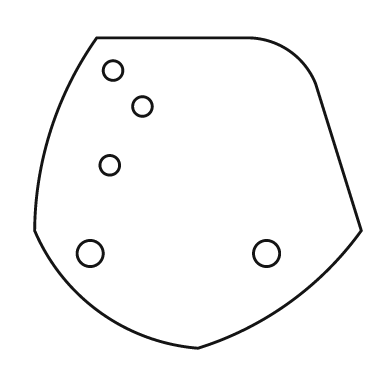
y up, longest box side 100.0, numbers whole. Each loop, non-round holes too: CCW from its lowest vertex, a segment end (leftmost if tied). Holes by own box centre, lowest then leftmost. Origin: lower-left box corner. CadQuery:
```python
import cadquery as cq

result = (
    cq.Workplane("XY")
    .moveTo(50.0, 0.0)
    .threePointArc((78.0, 14.0), (100.0, 36.0))
    .lineTo(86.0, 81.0)
    .threePointArc((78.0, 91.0), (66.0, 95.0))
    .lineTo(19.0, 95.0)
    .threePointArc((5.0, 67.0), (0.0, 36.0))
    .threePointArc((20.0, 11.0), (50.0, 0.0))
    .close()
    .moveTo(17.0, 29.0)
    .circle(4.0)
    .moveTo(71.0, 29.0)
    .circle(4.0)
    .moveTo(23.0, 56.0)
    .circle(3.0)
    .moveTo(33.0, 74.0)
    .circle(3.0)
    .moveTo(24.0, 85.0)
    .circle(3.0)
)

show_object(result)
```